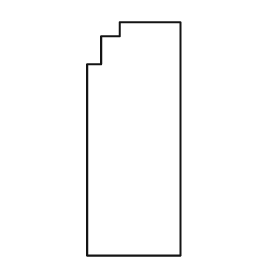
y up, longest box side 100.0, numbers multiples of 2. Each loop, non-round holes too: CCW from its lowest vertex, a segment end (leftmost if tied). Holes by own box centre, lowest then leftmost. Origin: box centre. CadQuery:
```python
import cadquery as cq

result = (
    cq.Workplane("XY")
    .moveTo(-20.0, -50.0)
    .lineTo(20.0, -50.0)
    .lineTo(20.0, 50.0)
    .lineTo(-6.0, 50.0)
    .lineTo(-6.0, 44.0)
    .lineTo(-14.0, 44.0)
    .lineTo(-14.0, 32.0)
    .lineTo(-20.0, 32.0)
    .close()
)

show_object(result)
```